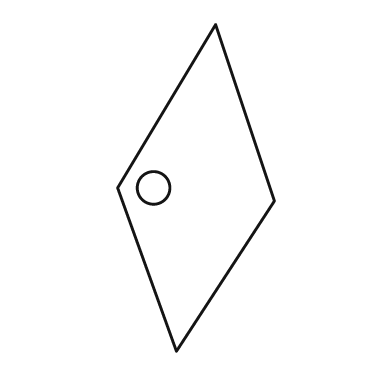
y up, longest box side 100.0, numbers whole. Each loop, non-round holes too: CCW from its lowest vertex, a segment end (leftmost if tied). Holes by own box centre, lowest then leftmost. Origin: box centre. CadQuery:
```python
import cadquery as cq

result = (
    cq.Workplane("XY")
    .moveTo(-6.0, -50.0)
    .lineTo(24.0, -4.0)
    .lineTo(6.0, 50.0)
    .lineTo(-24.0, 0.0)
    .close()
    .moveTo(-13.0, 0.0)
    .circle(5.0)
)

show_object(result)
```